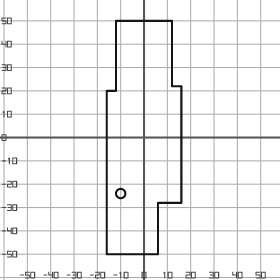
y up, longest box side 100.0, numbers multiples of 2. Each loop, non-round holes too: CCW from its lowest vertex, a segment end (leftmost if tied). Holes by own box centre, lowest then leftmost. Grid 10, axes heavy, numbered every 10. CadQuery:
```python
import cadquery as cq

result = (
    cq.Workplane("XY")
    .moveTo(-16.0, -50.0)
    .lineTo(6.0, -50.0)
    .lineTo(6.0, -28.0)
    .lineTo(16.0, -28.0)
    .lineTo(16.0, 22.0)
    .lineTo(12.0, 22.0)
    .lineTo(12.0, 50.0)
    .lineTo(-12.0, 50.0)
    .lineTo(-12.0, 20.0)
    .lineTo(-16.0, 20.0)
    .close()
    .moveTo(-10.0, -24.0)
    .circle(2.0)
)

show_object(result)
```